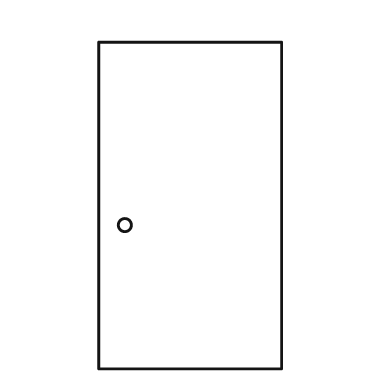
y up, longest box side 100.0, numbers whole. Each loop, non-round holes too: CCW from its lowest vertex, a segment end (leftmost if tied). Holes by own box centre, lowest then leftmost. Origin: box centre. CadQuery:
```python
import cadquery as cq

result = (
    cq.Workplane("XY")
    .moveTo(-28.0, -50.0)
    .lineTo(28.0, -50.0)
    .lineTo(28.0, 50.0)
    .lineTo(-28.0, 50.0)
    .close()
    .moveTo(-20.0, -6.0)
    .circle(2.0)
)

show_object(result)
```